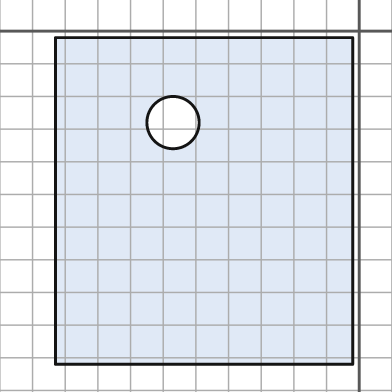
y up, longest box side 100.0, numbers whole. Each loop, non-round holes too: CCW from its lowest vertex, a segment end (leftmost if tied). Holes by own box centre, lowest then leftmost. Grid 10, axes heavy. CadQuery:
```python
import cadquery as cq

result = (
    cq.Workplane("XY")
    .moveTo(-93.0, -102.0)
    .lineTo(-2.0, -102.0)
    .lineTo(-2.0, -2.0)
    .lineTo(-93.0, -2.0)
    .close()
    .moveTo(-57.0, -28.0)
    .circle(8.0)
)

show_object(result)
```